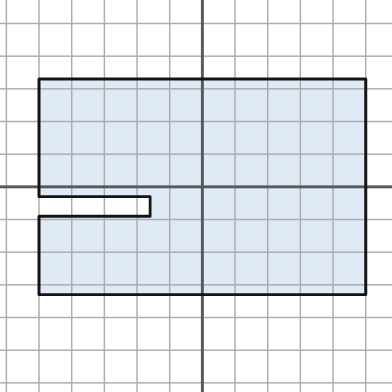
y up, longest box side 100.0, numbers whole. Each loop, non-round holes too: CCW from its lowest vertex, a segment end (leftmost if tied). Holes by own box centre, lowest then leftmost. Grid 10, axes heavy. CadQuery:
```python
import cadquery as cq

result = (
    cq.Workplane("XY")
    .moveTo(-50.0, -33.0)
    .lineTo(50.0, -33.0)
    .lineTo(50.0, 33.0)
    .lineTo(-50.0, 33.0)
    .lineTo(-50.0, -3.0)
    .lineTo(-16.0, -3.0)
    .lineTo(-16.0, -9.0)
    .lineTo(-50.0, -9.0)
    .close()
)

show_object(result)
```